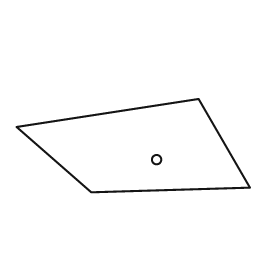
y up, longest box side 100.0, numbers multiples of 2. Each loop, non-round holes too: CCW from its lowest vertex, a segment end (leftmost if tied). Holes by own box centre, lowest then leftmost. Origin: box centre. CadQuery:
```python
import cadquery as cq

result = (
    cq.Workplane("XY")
    .moveTo(-18.0, -20.0)
    .lineTo(50.0, -18.0)
    .lineTo(28.0, 20.0)
    .lineTo(-50.0, 8.0)
    .close()
    .moveTo(10.0, -6.0)
    .circle(2.0)
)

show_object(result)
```